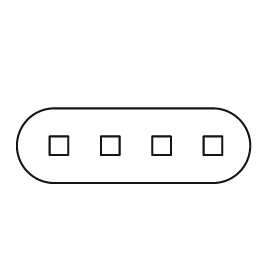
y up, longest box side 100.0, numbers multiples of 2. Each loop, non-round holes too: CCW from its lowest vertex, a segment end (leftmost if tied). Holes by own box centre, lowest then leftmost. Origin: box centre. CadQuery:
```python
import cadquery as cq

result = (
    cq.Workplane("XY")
    .moveTo(-34.0, -16.0)
    .lineTo(34.0, -16.0)
    .threePointArc((50.0, 0.0), (34.0, 16.0))
    .lineTo(-34.0, 16.0)
    .threePointArc((-50.0, 0.0), (-34.0, -16.0))
    .close()
    .moveTo(-36.0, -4.0)
    .lineTo(-28.0, -4.0)
    .lineTo(-28.0, 4.0)
    .lineTo(-36.0, 4.0)
    .close()
    .moveTo(-14.0, -4.0)
    .lineTo(-6.0, -4.0)
    .lineTo(-6.0, 4.0)
    .lineTo(-14.0, 4.0)
    .close()
    .moveTo(8.0, -4.0)
    .lineTo(16.0, -4.0)
    .lineTo(16.0, 4.0)
    .lineTo(8.0, 4.0)
    .close()
    .moveTo(30.0, -4.0)
    .lineTo(38.0, -4.0)
    .lineTo(38.0, 4.0)
    .lineTo(30.0, 4.0)
    .close()
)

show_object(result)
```